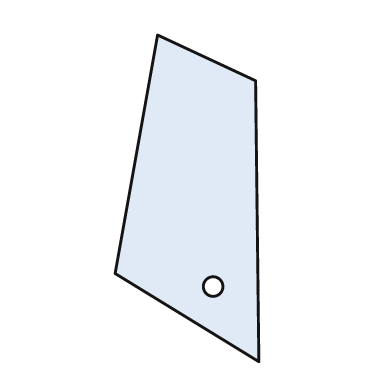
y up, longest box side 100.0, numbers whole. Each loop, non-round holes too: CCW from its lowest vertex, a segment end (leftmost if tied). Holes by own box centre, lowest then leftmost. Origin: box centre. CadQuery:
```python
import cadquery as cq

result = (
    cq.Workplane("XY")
    .moveTo(22.0, -50.0)
    .lineTo(21.0, 36.0)
    .lineTo(-9.0, 50.0)
    .lineTo(-22.0, -23.0)
    .close()
    .moveTo(8.0, -27.0)
    .circle(3.0)
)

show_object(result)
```